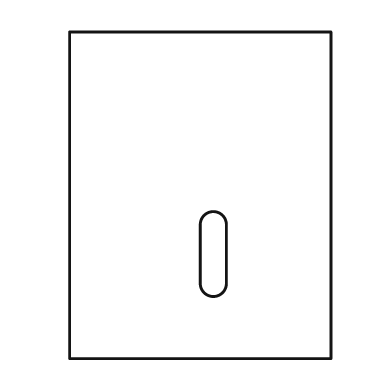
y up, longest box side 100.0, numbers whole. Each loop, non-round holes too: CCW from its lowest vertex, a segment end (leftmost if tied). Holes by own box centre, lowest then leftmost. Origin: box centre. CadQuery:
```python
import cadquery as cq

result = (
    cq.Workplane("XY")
    .moveTo(-40.0, -50.0)
    .lineTo(40.0, -50.0)
    .lineTo(40.0, 50.0)
    .lineTo(-40.0, 50.0)
    .close()
    .moveTo(0.0, -27.0)
    .threePointArc((4.0, -31.0), (8.0, -27.0))
    .lineTo(8.0, -9.0)
    .threePointArc((4.0, -5.0), (0.0, -9.0))
    .close()
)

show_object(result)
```